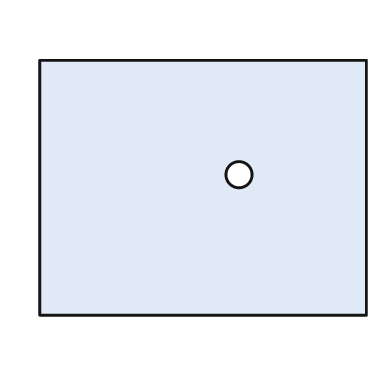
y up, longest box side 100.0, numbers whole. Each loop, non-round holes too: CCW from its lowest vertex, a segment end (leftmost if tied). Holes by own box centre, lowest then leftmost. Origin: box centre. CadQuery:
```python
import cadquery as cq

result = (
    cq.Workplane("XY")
    .moveTo(-50.0, -39.0)
    .lineTo(50.0, -39.0)
    .lineTo(50.0, 39.0)
    .lineTo(-50.0, 39.0)
    .close()
    .moveTo(11.0, 4.0)
    .circle(4.0)
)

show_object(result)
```